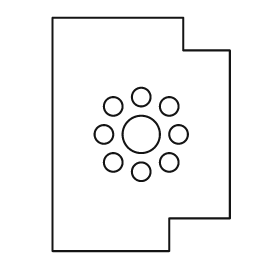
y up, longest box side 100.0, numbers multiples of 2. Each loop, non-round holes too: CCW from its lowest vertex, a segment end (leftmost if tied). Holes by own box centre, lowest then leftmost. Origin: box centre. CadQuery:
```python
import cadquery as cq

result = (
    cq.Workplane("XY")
    .moveTo(-38.0, -50.0)
    .lineTo(12.0, -50.0)
    .lineTo(12.0, -36.0)
    .lineTo(38.0, -36.0)
    .lineTo(38.0, 36.0)
    .lineTo(18.0, 36.0)
    .lineTo(18.0, 50.0)
    .lineTo(-38.0, 50.0)
    .close()
    .moveTo(0.0, -16.0)
    .circle(4.0)
    .moveTo(-12.0, -12.0)
    .circle(4.0)
    .moveTo(12.0, -12.0)
    .circle(4.0)
    .moveTo(-16.0, 0.0)
    .circle(4.0)
    .moveTo(0.0, 0.0)
    .circle(8.0)
    .moveTo(16.0, 0.0)
    .circle(4.0)
    .moveTo(-12.0, 12.0)
    .circle(4.0)
    .moveTo(12.0, 12.0)
    .circle(4.0)
    .moveTo(0.0, 16.0)
    .circle(4.0)
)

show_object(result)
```